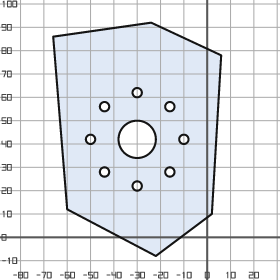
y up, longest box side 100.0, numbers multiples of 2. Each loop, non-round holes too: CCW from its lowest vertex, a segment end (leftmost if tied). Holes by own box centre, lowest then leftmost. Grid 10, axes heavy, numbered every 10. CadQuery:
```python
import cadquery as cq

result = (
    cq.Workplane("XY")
    .moveTo(-22.0, -8.0)
    .lineTo(2.0, 10.0)
    .lineTo(6.0, 78.0)
    .lineTo(-24.0, 92.0)
    .lineTo(-66.0, 86.0)
    .lineTo(-60.0, 12.0)
    .close()
    .moveTo(-30.0, 22.0)
    .circle(2.0)
    .moveTo(-44.0, 28.0)
    .circle(2.0)
    .moveTo(-16.0, 28.0)
    .circle(2.0)
    .moveTo(-50.0, 42.0)
    .circle(2.0)
    .moveTo(-30.0, 42.0)
    .circle(8.0)
    .moveTo(-10.0, 42.0)
    .circle(2.0)
    .moveTo(-44.0, 56.0)
    .circle(2.0)
    .moveTo(-16.0, 56.0)
    .circle(2.0)
    .moveTo(-30.0, 62.0)
    .circle(2.0)
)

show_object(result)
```